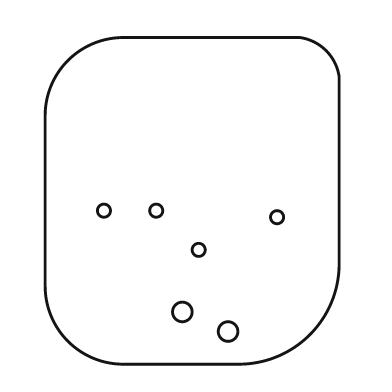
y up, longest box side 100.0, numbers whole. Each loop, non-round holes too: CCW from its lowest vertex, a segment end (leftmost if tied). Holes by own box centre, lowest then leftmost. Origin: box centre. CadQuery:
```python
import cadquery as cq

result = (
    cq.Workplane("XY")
    .moveTo(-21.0, -50.0)
    .lineTo(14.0, -50.0)
    .threePointArc((36.0, -41.0), (45.0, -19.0))
    .lineTo(45.0, 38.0)
    .threePointArc((41.0, 46.0), (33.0, 50.0))
    .lineTo(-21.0, 50.0)
    .threePointArc((-38.0, 43.0), (-45.0, 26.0))
    .lineTo(-45.0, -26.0)
    .threePointArc((-38.0, -43.0), (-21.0, -50.0))
    .close()
    .moveTo(11.0, -40.0)
    .circle(3.0)
    .moveTo(-3.0, -34.0)
    .circle(3.0)
    .moveTo(2.0, -15.0)
    .circle(2.0)
    .moveTo(26.0, -5.0)
    .circle(2.0)
    .moveTo(-27.0, -3.0)
    .circle(2.0)
    .moveTo(-11.0, -3.0)
    .circle(2.0)
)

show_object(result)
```